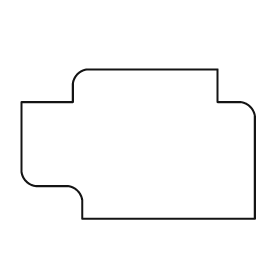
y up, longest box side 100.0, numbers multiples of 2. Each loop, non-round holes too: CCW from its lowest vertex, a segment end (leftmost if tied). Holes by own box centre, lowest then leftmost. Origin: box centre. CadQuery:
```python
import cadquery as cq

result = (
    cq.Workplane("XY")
    .moveTo(-24.0, -32.0)
    .lineTo(50.0, -32.0)
    .lineTo(50.0, 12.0)
    .threePointArc((48.0, 16.0), (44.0, 18.0))
    .lineTo(34.0, 18.0)
    .lineTo(34.0, 32.0)
    .lineTo(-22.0, 32.0)
    .threePointArc((-26.0, 30.0), (-28.0, 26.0))
    .lineTo(-28.0, 18.0)
    .lineTo(-50.0, 18.0)
    .lineTo(-50.0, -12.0)
    .threePointArc((-48.0, -16.0), (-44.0, -18.0))
    .lineTo(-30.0, -18.0)
    .threePointArc((-26.0, -20.0), (-24.0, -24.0))
    .close()
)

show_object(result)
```